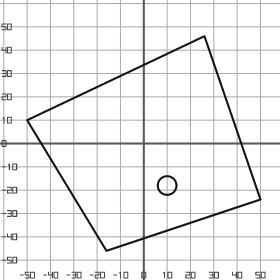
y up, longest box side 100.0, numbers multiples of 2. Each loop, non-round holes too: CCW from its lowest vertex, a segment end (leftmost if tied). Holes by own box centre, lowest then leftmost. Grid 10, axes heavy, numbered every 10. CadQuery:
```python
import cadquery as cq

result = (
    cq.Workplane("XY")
    .moveTo(-16.0, -46.0)
    .lineTo(50.0, -24.0)
    .lineTo(26.0, 46.0)
    .lineTo(-50.0, 10.0)
    .close()
    .moveTo(10.0, -18.0)
    .circle(4.0)
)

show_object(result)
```